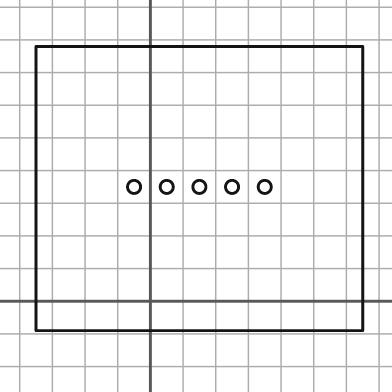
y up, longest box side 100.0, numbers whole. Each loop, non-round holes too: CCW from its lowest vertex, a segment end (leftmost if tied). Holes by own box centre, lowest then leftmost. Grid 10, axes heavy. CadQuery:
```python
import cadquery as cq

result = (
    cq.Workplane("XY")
    .moveTo(-35.0, -9.0)
    .lineTo(65.0, -9.0)
    .lineTo(65.0, 78.0)
    .lineTo(-35.0, 78.0)
    .close()
    .moveTo(-5.0, 35.0)
    .circle(2.0)
    .moveTo(5.0, 35.0)
    .circle(2.0)
    .moveTo(15.0, 35.0)
    .circle(2.0)
    .moveTo(25.0, 35.0)
    .circle(2.0)
    .moveTo(35.0, 35.0)
    .circle(2.0)
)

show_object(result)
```